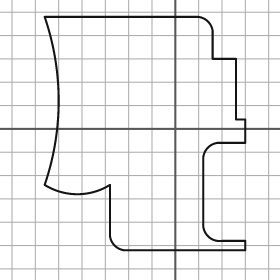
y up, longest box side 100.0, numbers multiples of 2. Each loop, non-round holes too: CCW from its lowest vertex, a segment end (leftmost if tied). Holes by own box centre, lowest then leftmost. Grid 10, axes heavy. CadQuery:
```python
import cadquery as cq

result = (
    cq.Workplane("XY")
    .moveTo(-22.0, -52.0)
    .lineTo(30.0, -52.0)
    .lineTo(30.0, -48.0)
    .lineTo(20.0, -48.0)
    .threePointArc((14.0, -46.0), (12.0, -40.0))
    .lineTo(12.0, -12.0)
    .threePointArc((14.0, -8.0), (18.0, -6.0))
    .lineTo(30.0, -6.0)
    .lineTo(30.0, 4.0)
    .lineTo(26.0, 4.0)
    .lineTo(26.0, 30.0)
    .lineTo(16.0, 30.0)
    .lineTo(16.0, 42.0)
    .threePointArc((14.0, 46.0), (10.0, 48.0))
    .lineTo(-56.0, 48.0)
    .threePointArc((-50.0, 12.0), (-56.0, -24.0))
    .threePointArc((-42.0, -28.0), (-28.0, -24.0))
    .lineTo(-28.0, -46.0)
    .threePointArc((-26.0, -50.0), (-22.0, -52.0))
    .close()
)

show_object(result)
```